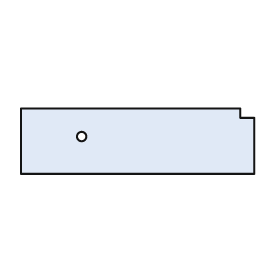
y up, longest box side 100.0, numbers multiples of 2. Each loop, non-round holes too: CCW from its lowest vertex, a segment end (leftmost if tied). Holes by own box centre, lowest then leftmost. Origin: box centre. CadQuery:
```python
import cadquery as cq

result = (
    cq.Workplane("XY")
    .moveTo(-50.0, -14.0)
    .lineTo(50.0, -14.0)
    .lineTo(50.0, 10.0)
    .lineTo(44.0, 10.0)
    .lineTo(44.0, 14.0)
    .lineTo(-50.0, 14.0)
    .close()
    .moveTo(-24.0, 2.0)
    .circle(2.0)
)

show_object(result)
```